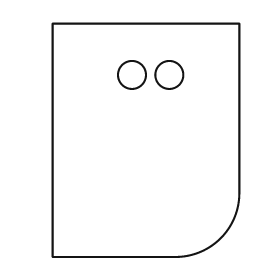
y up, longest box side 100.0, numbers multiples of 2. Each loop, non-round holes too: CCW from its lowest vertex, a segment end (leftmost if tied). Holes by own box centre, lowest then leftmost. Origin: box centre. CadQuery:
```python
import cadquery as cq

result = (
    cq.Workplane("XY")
    .moveTo(-40.0, -50.0)
    .lineTo(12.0, -50.0)
    .threePointArc((32.0, -42.0), (40.0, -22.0))
    .lineTo(40.0, 50.0)
    .lineTo(-40.0, 50.0)
    .close()
    .moveTo(-6.0, 28.0)
    .circle(6.0)
    .moveTo(10.0, 28.0)
    .circle(6.0)
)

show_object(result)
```